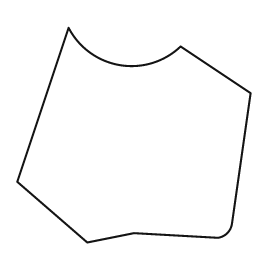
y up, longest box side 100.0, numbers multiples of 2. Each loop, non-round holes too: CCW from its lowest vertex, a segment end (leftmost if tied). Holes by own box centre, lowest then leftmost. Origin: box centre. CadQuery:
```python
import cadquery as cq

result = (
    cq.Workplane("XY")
    .moveTo(-20.0, -46.0)
    .lineTo(0.0, -42.0)
    .lineTo(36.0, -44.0)
    .threePointArc((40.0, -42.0), (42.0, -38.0))
    .lineTo(50.0, 18.0)
    .lineTo(20.0, 38.0)
    .threePointArc((-6.0, 30.0), (-28.0, 46.0))
    .lineTo(-50.0, -20.0)
    .close()
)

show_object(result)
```